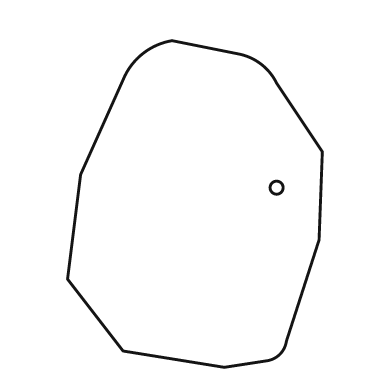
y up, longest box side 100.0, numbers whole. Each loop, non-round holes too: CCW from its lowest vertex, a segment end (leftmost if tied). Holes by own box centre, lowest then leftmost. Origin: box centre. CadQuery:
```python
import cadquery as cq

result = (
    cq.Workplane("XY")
    .moveTo(9.0, -50.0)
    .lineTo(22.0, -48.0)
    .threePointArc((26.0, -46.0), (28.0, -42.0))
    .lineTo(38.0, -11.0)
    .lineTo(39.0, 16.0)
    .lineTo(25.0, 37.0)
    .threePointArc((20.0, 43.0), (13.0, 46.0))
    .lineTo(-7.0, 50.0)
    .threePointArc((-16.0, 46.0), (-22.0, 38.0))
    .lineTo(-35.0, 9.0)
    .lineTo(-39.0, -23.0)
    .lineTo(-22.0, -45.0)
    .close()
    .moveTo(25.0, 5.0)
    .circle(2.0)
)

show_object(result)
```